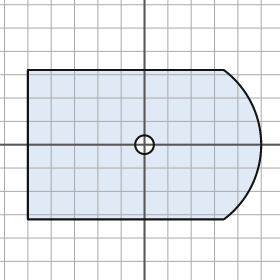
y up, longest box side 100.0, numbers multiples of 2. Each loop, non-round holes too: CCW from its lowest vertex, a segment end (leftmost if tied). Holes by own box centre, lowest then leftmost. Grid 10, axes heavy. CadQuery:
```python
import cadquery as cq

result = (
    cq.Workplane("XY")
    .moveTo(-50.0, -32.0)
    .lineTo(34.0, -32.0)
    .threePointArc((50.0, 0.0), (34.0, 32.0))
    .lineTo(-50.0, 32.0)
    .close()
    .moveTo(0.0, 0.0)
    .circle(4.0)
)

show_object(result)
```